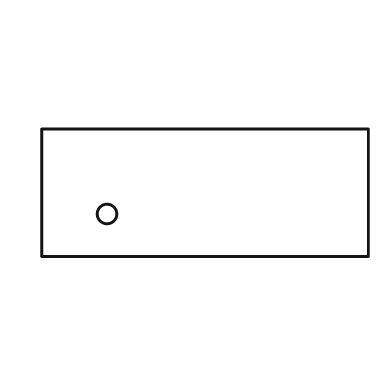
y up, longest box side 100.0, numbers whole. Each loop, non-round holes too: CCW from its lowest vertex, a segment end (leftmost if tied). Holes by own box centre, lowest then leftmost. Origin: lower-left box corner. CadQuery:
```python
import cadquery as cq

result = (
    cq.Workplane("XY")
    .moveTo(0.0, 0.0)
    .lineTo(100.0, 0.0)
    .lineTo(100.0, 39.0)
    .lineTo(0.0, 39.0)
    .close()
    .moveTo(20.0, 13.0)
    .circle(3.0)
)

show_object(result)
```